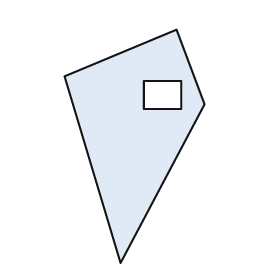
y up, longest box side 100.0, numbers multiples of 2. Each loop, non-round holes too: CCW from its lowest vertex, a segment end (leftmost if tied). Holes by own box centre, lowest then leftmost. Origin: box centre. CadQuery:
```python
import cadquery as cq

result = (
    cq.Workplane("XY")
    .moveTo(-6.0, -50.0)
    .lineTo(30.0, 18.0)
    .lineTo(18.0, 50.0)
    .lineTo(-30.0, 30.0)
    .close()
    .moveTo(4.0, 16.0)
    .lineTo(20.0, 16.0)
    .lineTo(20.0, 28.0)
    .lineTo(4.0, 28.0)
    .close()
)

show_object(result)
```